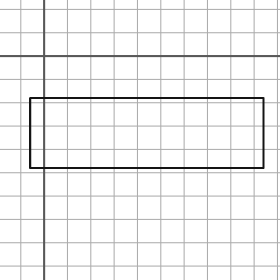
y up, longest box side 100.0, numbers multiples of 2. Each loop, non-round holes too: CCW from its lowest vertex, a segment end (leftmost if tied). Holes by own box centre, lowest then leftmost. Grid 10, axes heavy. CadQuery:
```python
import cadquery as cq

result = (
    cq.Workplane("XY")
    .moveTo(-6.0, -48.0)
    .lineTo(94.0, -48.0)
    .lineTo(94.0, -18.0)
    .lineTo(-6.0, -18.0)
    .close()
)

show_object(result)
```